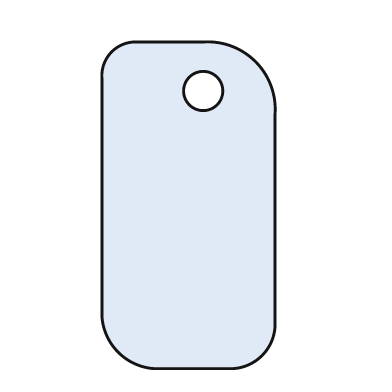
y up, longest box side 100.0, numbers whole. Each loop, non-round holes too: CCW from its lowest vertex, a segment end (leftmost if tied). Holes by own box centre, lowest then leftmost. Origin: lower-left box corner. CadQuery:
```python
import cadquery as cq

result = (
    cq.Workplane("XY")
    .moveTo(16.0, 0.0)
    .lineTo(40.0, 0.0)
    .threePointArc((49.0, 4.0), (53.0, 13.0))
    .lineTo(53.0, 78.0)
    .threePointArc((47.0, 94.0), (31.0, 100.0))
    .lineTo(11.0, 100.0)
    .threePointArc((3.0, 97.0), (0.0, 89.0))
    .lineTo(0.0, 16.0)
    .threePointArc((5.0, 5.0), (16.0, 0.0))
    .close()
    .moveTo(31.0, 85.0)
    .circle(6.0)
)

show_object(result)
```